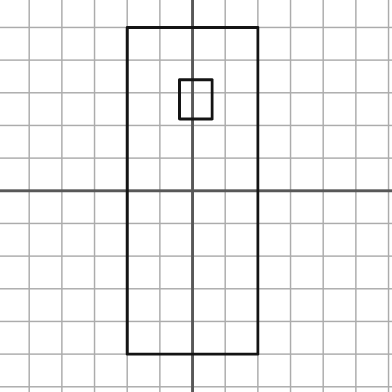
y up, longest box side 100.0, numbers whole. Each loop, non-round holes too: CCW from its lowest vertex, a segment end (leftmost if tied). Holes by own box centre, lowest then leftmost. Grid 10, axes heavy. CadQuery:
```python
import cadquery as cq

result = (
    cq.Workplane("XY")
    .moveTo(-20.0, -50.0)
    .lineTo(20.0, -50.0)
    .lineTo(20.0, 50.0)
    .lineTo(-20.0, 50.0)
    .close()
    .moveTo(-4.0, 22.0)
    .lineTo(6.0, 22.0)
    .lineTo(6.0, 34.0)
    .lineTo(-4.0, 34.0)
    .close()
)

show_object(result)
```